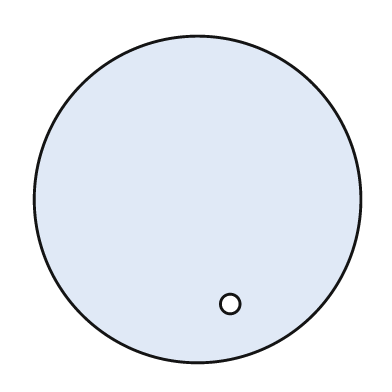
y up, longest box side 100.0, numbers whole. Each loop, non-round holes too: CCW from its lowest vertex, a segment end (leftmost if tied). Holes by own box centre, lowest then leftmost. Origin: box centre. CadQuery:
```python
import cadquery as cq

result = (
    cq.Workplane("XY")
    .moveTo(0.0, 0.0)
    .circle(50.0)
    .moveTo(10.0, -32.0)
    .circle(3.0)
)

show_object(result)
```